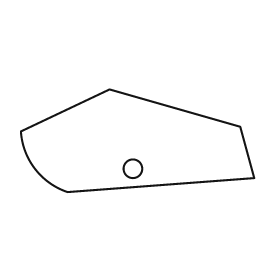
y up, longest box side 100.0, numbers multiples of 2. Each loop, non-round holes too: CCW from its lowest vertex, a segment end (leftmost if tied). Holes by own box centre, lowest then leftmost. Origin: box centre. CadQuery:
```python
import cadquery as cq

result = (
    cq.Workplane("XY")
    .moveTo(-30.0, -22.0)
    .lineTo(50.0, -16.0)
    .lineTo(44.0, 6.0)
    .lineTo(-12.0, 22.0)
    .lineTo(-50.0, 4.0)
    .threePointArc((-44.0, -12.0), (-30.0, -22.0))
    .close()
    .moveTo(-2.0, -12.0)
    .circle(4.0)
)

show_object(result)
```